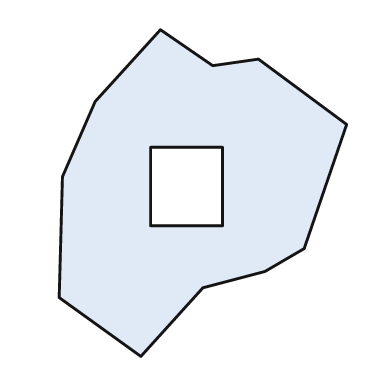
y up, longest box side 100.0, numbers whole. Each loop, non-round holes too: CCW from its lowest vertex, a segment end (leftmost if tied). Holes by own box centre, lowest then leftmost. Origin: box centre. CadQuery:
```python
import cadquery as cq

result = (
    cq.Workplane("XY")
    .moveTo(-19.0, -50.0)
    .lineTo(0.0, -29.0)
    .lineTo(19.0, -24.0)
    .lineTo(31.0, -17.0)
    .lineTo(44.0, 21.0)
    .lineTo(17.0, 41.0)
    .lineTo(3.0, 39.0)
    .lineTo(-13.0, 50.0)
    .lineTo(-33.0, 28.0)
    .lineTo(-43.0, 5.0)
    .lineTo(-44.0, -32.0)
    .close()
    .moveTo(-16.0, -10.0)
    .lineTo(6.0, -10.0)
    .lineTo(6.0, 14.0)
    .lineTo(-16.0, 14.0)
    .close()
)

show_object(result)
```